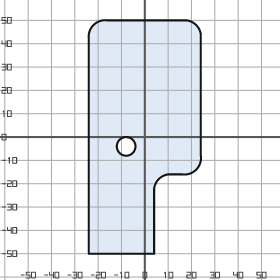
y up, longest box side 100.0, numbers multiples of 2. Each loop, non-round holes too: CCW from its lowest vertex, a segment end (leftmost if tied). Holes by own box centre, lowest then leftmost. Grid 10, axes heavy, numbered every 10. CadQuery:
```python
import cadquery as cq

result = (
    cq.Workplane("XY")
    .moveTo(-24.0, -50.0)
    .lineTo(4.0, -50.0)
    .lineTo(4.0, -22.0)
    .threePointArc((6.0, -18.0), (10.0, -16.0))
    .lineTo(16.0, -16.0)
    .threePointArc((22.0, -14.0), (24.0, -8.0))
    .lineTo(24.0, 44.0)
    .threePointArc((22.0, 48.0), (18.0, 50.0))
    .lineTo(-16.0, 50.0)
    .threePointArc((-22.0, 48.0), (-24.0, 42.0))
    .close()
    .moveTo(-8.0, -4.0)
    .circle(4.0)
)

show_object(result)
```